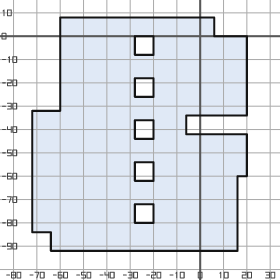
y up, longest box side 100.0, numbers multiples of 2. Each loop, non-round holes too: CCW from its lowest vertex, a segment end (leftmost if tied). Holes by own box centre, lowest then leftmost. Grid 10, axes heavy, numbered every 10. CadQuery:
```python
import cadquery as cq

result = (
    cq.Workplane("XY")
    .moveTo(-64.0, -92.0)
    .lineTo(16.0, -92.0)
    .lineTo(16.0, -60.0)
    .lineTo(20.0, -60.0)
    .lineTo(20.0, -42.0)
    .lineTo(-6.0, -42.0)
    .lineTo(-6.0, -34.0)
    .lineTo(20.0, -34.0)
    .lineTo(20.0, 0.0)
    .lineTo(6.0, 0.0)
    .lineTo(6.0, 8.0)
    .lineTo(-60.0, 8.0)
    .lineTo(-60.0, -32.0)
    .lineTo(-72.0, -32.0)
    .lineTo(-72.0, -84.0)
    .lineTo(-64.0, -84.0)
    .close()
    .moveTo(-28.0, -80.0)
    .lineTo(-20.0, -80.0)
    .lineTo(-20.0, -72.0)
    .lineTo(-28.0, -72.0)
    .close()
    .moveTo(-28.0, -62.0)
    .lineTo(-20.0, -62.0)
    .lineTo(-20.0, -54.0)
    .lineTo(-28.0, -54.0)
    .close()
    .moveTo(-28.0, -44.0)
    .lineTo(-20.0, -44.0)
    .lineTo(-20.0, -36.0)
    .lineTo(-28.0, -36.0)
    .close()
    .moveTo(-28.0, -26.0)
    .lineTo(-20.0, -26.0)
    .lineTo(-20.0, -18.0)
    .lineTo(-28.0, -18.0)
    .close()
    .moveTo(-28.0, -8.0)
    .lineTo(-20.0, -8.0)
    .lineTo(-20.0, 0.0)
    .lineTo(-28.0, 0.0)
    .close()
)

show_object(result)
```